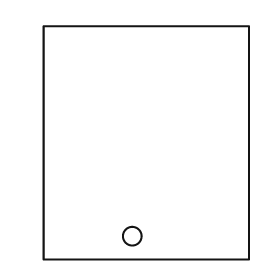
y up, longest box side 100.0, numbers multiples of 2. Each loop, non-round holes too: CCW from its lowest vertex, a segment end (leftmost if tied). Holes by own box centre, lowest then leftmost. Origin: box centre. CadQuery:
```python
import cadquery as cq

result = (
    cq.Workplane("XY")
    .moveTo(-44.0, -50.0)
    .lineTo(44.0, -50.0)
    .lineTo(44.0, 50.0)
    .lineTo(-44.0, 50.0)
    .close()
    .moveTo(-6.0, -40.0)
    .circle(4.0)
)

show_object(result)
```